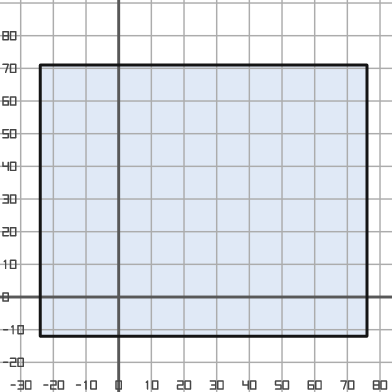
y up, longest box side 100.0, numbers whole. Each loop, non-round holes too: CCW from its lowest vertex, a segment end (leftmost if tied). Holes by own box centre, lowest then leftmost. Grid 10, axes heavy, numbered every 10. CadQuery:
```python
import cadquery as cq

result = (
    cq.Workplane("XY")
    .moveTo(-24.0, -12.0)
    .lineTo(76.0, -12.0)
    .lineTo(76.0, 71.0)
    .lineTo(-24.0, 71.0)
    .close()
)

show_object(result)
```